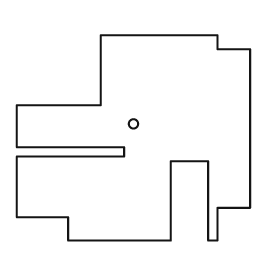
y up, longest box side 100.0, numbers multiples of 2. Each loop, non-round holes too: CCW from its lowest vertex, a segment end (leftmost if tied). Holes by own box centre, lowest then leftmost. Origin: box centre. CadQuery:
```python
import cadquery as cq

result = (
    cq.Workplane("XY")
    .moveTo(-28.0, -44.0)
    .lineTo(16.0, -44.0)
    .lineTo(16.0, -10.0)
    .lineTo(32.0, -10.0)
    .lineTo(32.0, -44.0)
    .lineTo(36.0, -44.0)
    .lineTo(36.0, -30.0)
    .lineTo(50.0, -30.0)
    .lineTo(50.0, 38.0)
    .lineTo(36.0, 38.0)
    .lineTo(36.0, 44.0)
    .lineTo(-14.0, 44.0)
    .lineTo(-14.0, 14.0)
    .lineTo(-50.0, 14.0)
    .lineTo(-50.0, -4.0)
    .lineTo(-4.0, -4.0)
    .lineTo(-4.0, -8.0)
    .lineTo(-50.0, -8.0)
    .lineTo(-50.0, -34.0)
    .lineTo(-28.0, -34.0)
    .close()
    .moveTo(0.0, 6.0)
    .circle(2.0)
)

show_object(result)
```